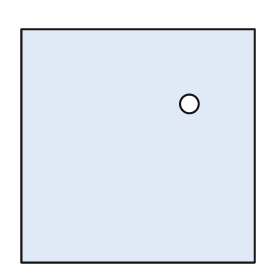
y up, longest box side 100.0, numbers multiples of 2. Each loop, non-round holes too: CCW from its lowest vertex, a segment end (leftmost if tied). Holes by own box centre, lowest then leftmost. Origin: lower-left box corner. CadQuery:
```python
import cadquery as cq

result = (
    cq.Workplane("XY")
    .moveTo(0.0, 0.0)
    .lineTo(100.0, 0.0)
    .lineTo(100.0, 100.0)
    .lineTo(0.0, 100.0)
    .close()
    .moveTo(72.0, 68.0)
    .circle(4.0)
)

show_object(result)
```